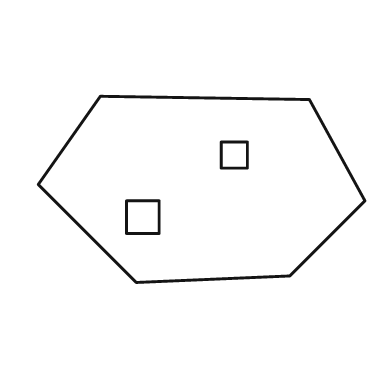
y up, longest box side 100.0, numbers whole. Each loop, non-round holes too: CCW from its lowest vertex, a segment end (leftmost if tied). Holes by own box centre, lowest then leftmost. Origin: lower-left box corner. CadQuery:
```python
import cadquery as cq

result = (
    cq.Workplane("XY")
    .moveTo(30.0, 0.0)
    .lineTo(77.0, 2.0)
    .lineTo(100.0, 25.0)
    .lineTo(83.0, 56.0)
    .lineTo(19.0, 57.0)
    .lineTo(0.0, 30.0)
    .close()
    .moveTo(27.0, 15.0)
    .lineTo(37.0, 15.0)
    .lineTo(37.0, 25.0)
    .lineTo(27.0, 25.0)
    .close()
    .moveTo(56.0, 35.0)
    .lineTo(64.0, 35.0)
    .lineTo(64.0, 43.0)
    .lineTo(56.0, 43.0)
    .close()
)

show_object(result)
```